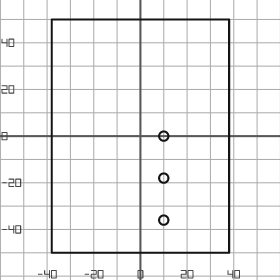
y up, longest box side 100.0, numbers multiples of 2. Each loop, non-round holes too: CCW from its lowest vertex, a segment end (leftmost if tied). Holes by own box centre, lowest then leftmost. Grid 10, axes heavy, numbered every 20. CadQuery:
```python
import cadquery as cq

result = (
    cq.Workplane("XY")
    .moveTo(-38.0, -50.0)
    .lineTo(38.0, -50.0)
    .lineTo(38.0, 50.0)
    .lineTo(-38.0, 50.0)
    .close()
    .moveTo(10.0, -36.0)
    .circle(2.0)
    .moveTo(10.0, -18.0)
    .circle(2.0)
    .moveTo(10.0, 0.0)
    .circle(2.0)
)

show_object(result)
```